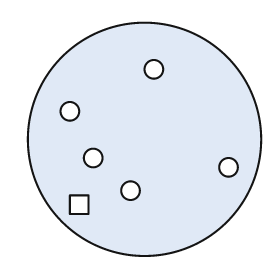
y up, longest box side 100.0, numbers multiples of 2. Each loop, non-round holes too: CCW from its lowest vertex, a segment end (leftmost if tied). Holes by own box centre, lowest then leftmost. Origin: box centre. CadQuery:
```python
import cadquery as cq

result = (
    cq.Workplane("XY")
    .moveTo(0.0, 0.0)
    .circle(50.0)
    .moveTo(-32.0, -32.0)
    .lineTo(-24.0, -32.0)
    .lineTo(-24.0, -24.0)
    .lineTo(-32.0, -24.0)
    .close()
    .moveTo(-6.0, -22.0)
    .circle(4.0)
    .moveTo(36.0, -12.0)
    .circle(4.0)
    .moveTo(-22.0, -8.0)
    .circle(4.0)
    .moveTo(-32.0, 12.0)
    .circle(4.0)
    .moveTo(4.0, 30.0)
    .circle(4.0)
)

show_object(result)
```